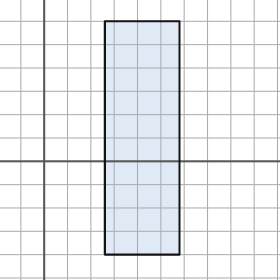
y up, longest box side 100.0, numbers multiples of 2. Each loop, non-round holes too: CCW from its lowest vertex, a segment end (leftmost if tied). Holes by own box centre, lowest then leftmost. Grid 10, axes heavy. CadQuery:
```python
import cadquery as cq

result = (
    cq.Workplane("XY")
    .moveTo(26.0, -40.0)
    .lineTo(58.0, -40.0)
    .lineTo(58.0, 60.0)
    .lineTo(26.0, 60.0)
    .close()
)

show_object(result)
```